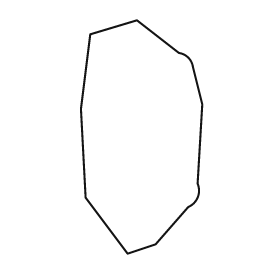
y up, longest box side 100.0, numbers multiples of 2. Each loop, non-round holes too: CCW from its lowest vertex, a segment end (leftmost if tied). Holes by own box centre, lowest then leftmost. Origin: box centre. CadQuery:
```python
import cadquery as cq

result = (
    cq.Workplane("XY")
    .moveTo(-6.0, -50.0)
    .lineTo(6.0, -46.0)
    .lineTo(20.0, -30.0)
    .threePointArc((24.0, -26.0), (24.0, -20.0))
    .lineTo(26.0, 14.0)
    .lineTo(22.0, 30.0)
    .threePointArc((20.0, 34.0), (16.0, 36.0))
    .lineTo(-2.0, 50.0)
    .lineTo(-22.0, 44.0)
    .lineTo(-26.0, 12.0)
    .lineTo(-24.0, -26.0)
    .close()
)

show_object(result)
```